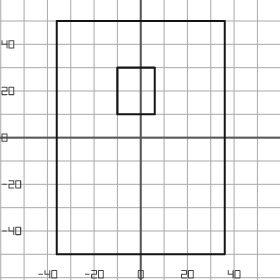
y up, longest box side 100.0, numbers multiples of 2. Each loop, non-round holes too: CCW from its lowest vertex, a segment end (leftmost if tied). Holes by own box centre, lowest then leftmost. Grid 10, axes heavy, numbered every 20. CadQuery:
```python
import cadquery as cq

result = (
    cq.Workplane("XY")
    .moveTo(-36.0, -50.0)
    .lineTo(36.0, -50.0)
    .lineTo(36.0, 50.0)
    .lineTo(-36.0, 50.0)
    .close()
    .moveTo(-10.0, 10.0)
    .lineTo(6.0, 10.0)
    .lineTo(6.0, 30.0)
    .lineTo(-10.0, 30.0)
    .close()
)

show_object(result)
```